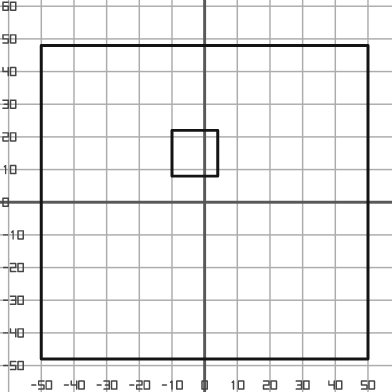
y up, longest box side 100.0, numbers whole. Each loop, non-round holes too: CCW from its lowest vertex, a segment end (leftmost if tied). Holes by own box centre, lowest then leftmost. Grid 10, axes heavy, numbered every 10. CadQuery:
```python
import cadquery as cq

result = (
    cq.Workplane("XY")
    .moveTo(-50.0, -48.0)
    .lineTo(50.0, -48.0)
    .lineTo(50.0, 48.0)
    .lineTo(-50.0, 48.0)
    .close()
    .moveTo(-10.0, 8.0)
    .lineTo(4.0, 8.0)
    .lineTo(4.0, 22.0)
    .lineTo(-10.0, 22.0)
    .close()
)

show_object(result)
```